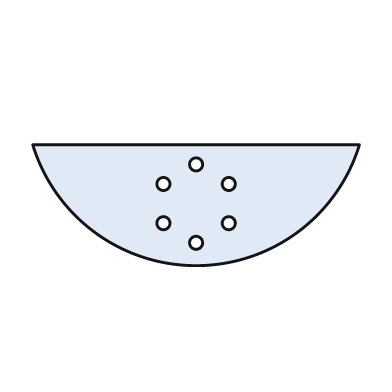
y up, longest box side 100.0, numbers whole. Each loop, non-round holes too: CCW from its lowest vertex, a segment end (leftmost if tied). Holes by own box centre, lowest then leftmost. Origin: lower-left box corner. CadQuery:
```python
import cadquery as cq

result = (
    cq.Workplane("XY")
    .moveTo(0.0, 37.0)
    .threePointArc((50.0, 0.0), (100.0, 37.0))
    .close()
    .moveTo(50.0, 7.0)
    .circle(2.0)
    .moveTo(40.0, 13.0)
    .circle(2.0)
    .moveTo(60.0, 13.0)
    .circle(2.0)
    .moveTo(40.0, 25.0)
    .circle(2.0)
    .moveTo(60.0, 25.0)
    .circle(2.0)
    .moveTo(50.0, 31.0)
    .circle(2.0)
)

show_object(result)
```